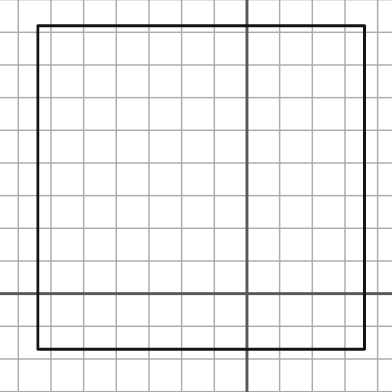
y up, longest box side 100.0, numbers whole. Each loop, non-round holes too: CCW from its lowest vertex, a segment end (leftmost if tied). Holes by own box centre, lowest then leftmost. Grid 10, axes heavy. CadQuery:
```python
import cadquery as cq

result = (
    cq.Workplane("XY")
    .moveTo(-64.0, -17.0)
    .lineTo(36.0, -17.0)
    .lineTo(36.0, 82.0)
    .lineTo(-64.0, 82.0)
    .close()
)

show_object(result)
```